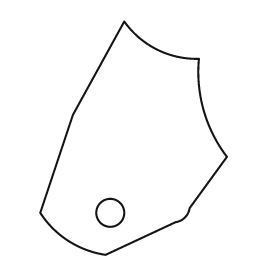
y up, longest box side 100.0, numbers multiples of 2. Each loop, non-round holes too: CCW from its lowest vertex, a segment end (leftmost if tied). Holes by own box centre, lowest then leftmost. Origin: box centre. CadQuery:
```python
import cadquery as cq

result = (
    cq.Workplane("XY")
    .moveTo(-12.0, -50.0)
    .lineTo(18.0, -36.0)
    .threePointArc((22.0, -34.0), (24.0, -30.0))
    .lineTo(40.0, -8.0)
    .threePointArc((30.0, 12.0), (28.0, 34.0))
    .threePointArc((10.0, 38.0), (-4.0, 50.0))
    .lineTo(-26.0, 10.0)
    .lineTo(-40.0, -32.0)
    .threePointArc((-28.0, -44.0), (-12.0, -50.0))
    .close()
    .moveTo(-10.0, -32.0)
    .circle(6.0)
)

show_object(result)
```